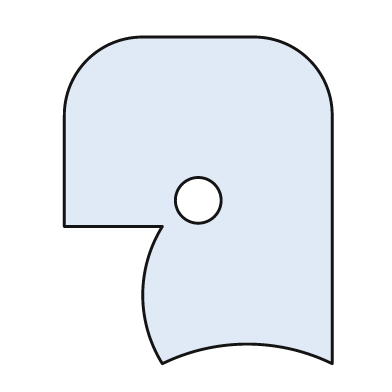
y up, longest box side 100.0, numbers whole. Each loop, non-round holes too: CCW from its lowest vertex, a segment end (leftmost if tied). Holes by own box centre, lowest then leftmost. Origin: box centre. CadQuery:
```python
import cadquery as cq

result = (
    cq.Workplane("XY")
    .moveTo(-11.0, -50.0)
    .threePointArc((15.0, -44.0), (41.0, -50.0))
    .lineTo(41.0, 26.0)
    .threePointArc((34.0, 43.0), (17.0, 50.0))
    .lineTo(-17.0, 50.0)
    .threePointArc((-34.0, 43.0), (-41.0, 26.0))
    .lineTo(-41.0, -8.0)
    .lineTo(-11.0, -8.0)
    .threePointArc((-17.0, -29.0), (-11.0, -50.0))
    .close()
    .moveTo(0.0, 0.0)
    .circle(7.0)
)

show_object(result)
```